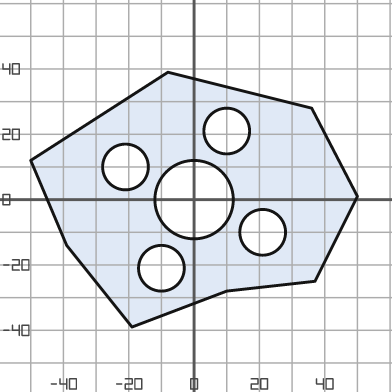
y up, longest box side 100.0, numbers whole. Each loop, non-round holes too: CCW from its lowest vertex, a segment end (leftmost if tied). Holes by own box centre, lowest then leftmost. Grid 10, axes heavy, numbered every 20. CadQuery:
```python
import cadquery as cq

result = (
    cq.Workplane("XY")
    .moveTo(-19.0, -39.0)
    .lineTo(10.0, -28.0)
    .lineTo(37.0, -25.0)
    .lineTo(50.0, 1.0)
    .lineTo(36.0, 28.0)
    .lineTo(-8.0, 39.0)
    .lineTo(-50.0, 12.0)
    .lineTo(-39.0, -14.0)
    .close()
    .moveTo(-10.0, -21.0)
    .circle(7.0)
    .moveTo(21.0, -10.0)
    .circle(7.0)
    .moveTo(0.0, 0.0)
    .circle(12.0)
    .moveTo(-21.0, 10.0)
    .circle(7.0)
    .moveTo(10.0, 21.0)
    .circle(7.0)
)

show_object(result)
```